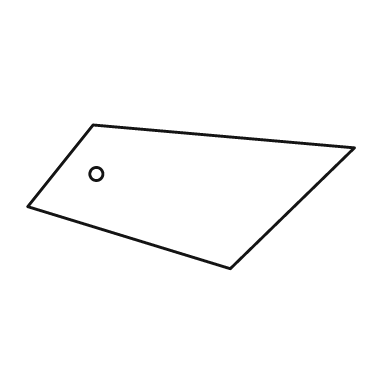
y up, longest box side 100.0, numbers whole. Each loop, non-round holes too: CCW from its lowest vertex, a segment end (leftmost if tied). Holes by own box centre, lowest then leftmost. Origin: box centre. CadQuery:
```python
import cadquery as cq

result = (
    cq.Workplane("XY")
    .moveTo(12.0, -22.0)
    .lineTo(50.0, 15.0)
    .lineTo(-30.0, 22.0)
    .lineTo(-50.0, -3.0)
    .close()
    .moveTo(-29.0, 7.0)
    .circle(2.0)
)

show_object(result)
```